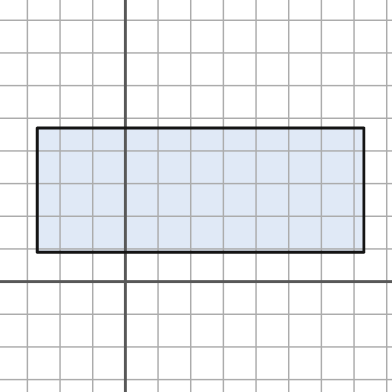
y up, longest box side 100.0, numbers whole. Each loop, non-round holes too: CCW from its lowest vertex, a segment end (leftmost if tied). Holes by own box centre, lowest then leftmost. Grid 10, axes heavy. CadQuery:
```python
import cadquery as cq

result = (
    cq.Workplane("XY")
    .moveTo(-27.0, 9.0)
    .lineTo(73.0, 9.0)
    .lineTo(73.0, 47.0)
    .lineTo(-27.0, 47.0)
    .close()
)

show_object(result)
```